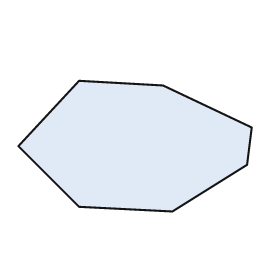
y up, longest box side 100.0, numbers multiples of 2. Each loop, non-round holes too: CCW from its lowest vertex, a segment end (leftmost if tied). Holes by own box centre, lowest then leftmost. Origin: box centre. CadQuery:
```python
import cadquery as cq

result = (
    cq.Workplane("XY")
    .moveTo(16.0, -28.0)
    .lineTo(48.0, -8.0)
    .lineTo(50.0, 8.0)
    .lineTo(12.0, 26.0)
    .lineTo(-24.0, 28.0)
    .lineTo(-50.0, 0.0)
    .lineTo(-24.0, -26.0)
    .close()
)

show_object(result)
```